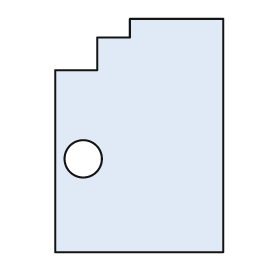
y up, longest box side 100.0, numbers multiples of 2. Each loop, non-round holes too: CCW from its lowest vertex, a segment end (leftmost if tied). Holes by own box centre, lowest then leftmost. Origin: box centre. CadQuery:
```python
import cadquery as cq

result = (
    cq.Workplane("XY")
    .moveTo(-36.0, -50.0)
    .lineTo(36.0, -50.0)
    .lineTo(36.0, 50.0)
    .lineTo(-4.0, 50.0)
    .lineTo(-4.0, 42.0)
    .lineTo(-18.0, 42.0)
    .lineTo(-18.0, 28.0)
    .lineTo(-36.0, 28.0)
    .close()
    .moveTo(-24.0, -10.0)
    .circle(8.0)
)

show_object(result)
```